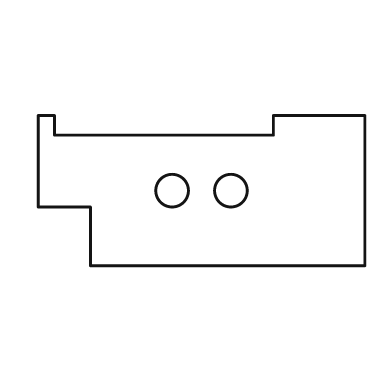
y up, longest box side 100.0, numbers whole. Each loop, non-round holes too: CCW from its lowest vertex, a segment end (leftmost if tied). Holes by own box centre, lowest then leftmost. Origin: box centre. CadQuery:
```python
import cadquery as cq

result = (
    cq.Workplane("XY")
    .moveTo(-34.0, -23.0)
    .lineTo(50.0, -23.0)
    .lineTo(50.0, 23.0)
    .lineTo(22.0, 23.0)
    .lineTo(22.0, 17.0)
    .lineTo(-45.0, 17.0)
    .lineTo(-45.0, 23.0)
    .lineTo(-50.0, 23.0)
    .lineTo(-50.0, -5.0)
    .lineTo(-34.0, -5.0)
    .close()
    .moveTo(-9.0, 0.0)
    .circle(5.0)
    .moveTo(9.0, 0.0)
    .circle(5.0)
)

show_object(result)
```